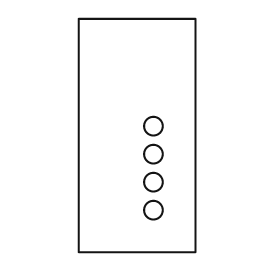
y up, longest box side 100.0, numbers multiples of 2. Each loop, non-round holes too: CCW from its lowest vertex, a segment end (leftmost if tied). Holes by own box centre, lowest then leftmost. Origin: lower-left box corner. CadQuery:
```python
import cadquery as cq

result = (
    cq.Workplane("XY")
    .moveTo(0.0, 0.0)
    .lineTo(50.0, 0.0)
    .lineTo(50.0, 100.0)
    .lineTo(0.0, 100.0)
    .close()
    .moveTo(32.0, 18.0)
    .circle(4.0)
    .moveTo(32.0, 30.0)
    .circle(4.0)
    .moveTo(32.0, 42.0)
    .circle(4.0)
    .moveTo(32.0, 54.0)
    .circle(4.0)
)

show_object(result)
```